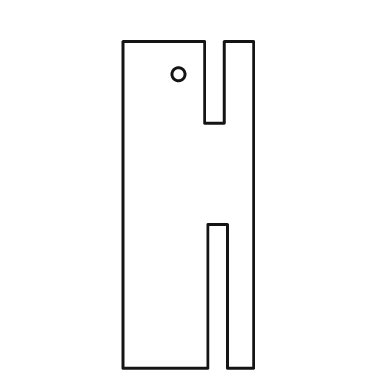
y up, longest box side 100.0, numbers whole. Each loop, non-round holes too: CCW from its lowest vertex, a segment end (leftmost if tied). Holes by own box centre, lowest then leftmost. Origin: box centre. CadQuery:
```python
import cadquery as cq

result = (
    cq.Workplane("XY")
    .moveTo(-20.0, -50.0)
    .lineTo(6.0, -50.0)
    .lineTo(6.0, -6.0)
    .lineTo(12.0, -6.0)
    .lineTo(12.0, -50.0)
    .lineTo(20.0, -50.0)
    .lineTo(20.0, 50.0)
    .lineTo(11.0, 50.0)
    .lineTo(11.0, 25.0)
    .lineTo(5.0, 25.0)
    .lineTo(5.0, 50.0)
    .lineTo(-20.0, 50.0)
    .close()
    .moveTo(-3.0, 40.0)
    .circle(2.0)
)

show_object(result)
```